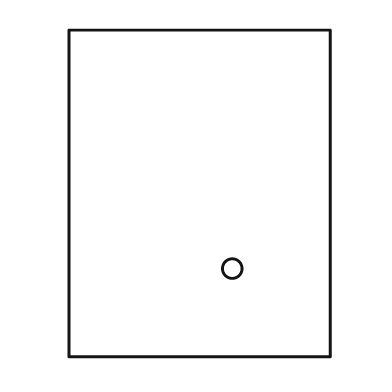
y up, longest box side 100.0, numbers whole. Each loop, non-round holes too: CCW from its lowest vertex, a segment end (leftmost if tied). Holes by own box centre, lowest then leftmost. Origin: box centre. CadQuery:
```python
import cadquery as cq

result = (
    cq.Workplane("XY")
    .moveTo(-40.0, -50.0)
    .lineTo(40.0, -50.0)
    .lineTo(40.0, 50.0)
    .lineTo(-40.0, 50.0)
    .close()
    .moveTo(10.0, -23.0)
    .circle(3.0)
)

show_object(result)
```